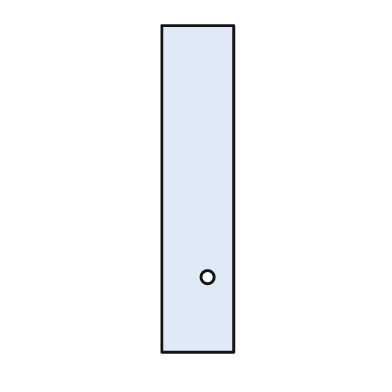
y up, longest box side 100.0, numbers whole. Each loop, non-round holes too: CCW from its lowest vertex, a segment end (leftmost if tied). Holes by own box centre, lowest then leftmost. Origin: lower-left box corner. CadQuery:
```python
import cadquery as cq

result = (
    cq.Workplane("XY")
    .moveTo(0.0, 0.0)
    .lineTo(22.0, 0.0)
    .lineTo(22.0, 100.0)
    .lineTo(0.0, 100.0)
    .close()
    .moveTo(14.0, 23.0)
    .circle(2.0)
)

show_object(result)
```